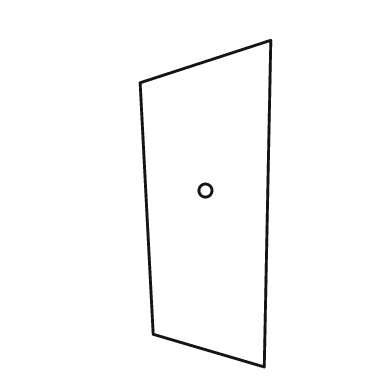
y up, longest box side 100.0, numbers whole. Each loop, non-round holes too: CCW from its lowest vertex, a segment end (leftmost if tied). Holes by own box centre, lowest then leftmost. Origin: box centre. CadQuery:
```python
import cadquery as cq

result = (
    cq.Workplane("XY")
    .moveTo(18.0, -50.0)
    .lineTo(20.0, 50.0)
    .lineTo(-20.0, 37.0)
    .lineTo(-16.0, -40.0)
    .close()
    .moveTo(0.0, 4.0)
    .circle(2.0)
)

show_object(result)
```